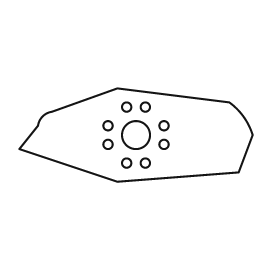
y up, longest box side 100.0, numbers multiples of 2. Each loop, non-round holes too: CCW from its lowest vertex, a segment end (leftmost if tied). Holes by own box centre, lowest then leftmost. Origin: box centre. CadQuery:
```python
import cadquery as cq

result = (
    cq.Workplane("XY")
    .moveTo(-8.0, -20.0)
    .lineTo(44.0, -16.0)
    .lineTo(50.0, 0.0)
    .threePointArc((46.0, 8.0), (40.0, 14.0))
    .lineTo(-8.0, 20.0)
    .lineTo(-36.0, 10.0)
    .threePointArc((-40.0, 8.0), (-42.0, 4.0))
    .lineTo(-50.0, -6.0)
    .close()
    .moveTo(-4.0, -12.0)
    .circle(2.0)
    .moveTo(4.0, -12.0)
    .circle(2.0)
    .moveTo(-12.0, -4.0)
    .circle(2.0)
    .moveTo(12.0, -4.0)
    .circle(2.0)
    .moveTo(0.0, 0.0)
    .circle(6.0)
    .moveTo(-12.0, 4.0)
    .circle(2.0)
    .moveTo(12.0, 4.0)
    .circle(2.0)
    .moveTo(-4.0, 12.0)
    .circle(2.0)
    .moveTo(4.0, 12.0)
    .circle(2.0)
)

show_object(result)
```